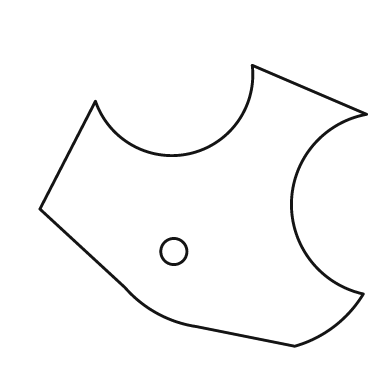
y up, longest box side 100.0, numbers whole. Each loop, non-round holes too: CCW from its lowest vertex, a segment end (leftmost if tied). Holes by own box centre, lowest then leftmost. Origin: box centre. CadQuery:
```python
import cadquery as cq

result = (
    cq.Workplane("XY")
    .moveTo(28.0, -43.0)
    .threePointArc((40.0, -37.0), (49.0, -27.0))
    .threePointArc((27.0, 1.0), (50.0, 28.0))
    .lineTo(15.0, 43.0)
    .threePointArc((-4.0, 16.0), (-33.0, 32.0))
    .lineTo(-50.0, -1.0)
    .lineTo(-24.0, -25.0)
    .threePointArc((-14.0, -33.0), (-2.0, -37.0))
    .close()
    .moveTo(-9.0, -14.0)
    .circle(4.0)
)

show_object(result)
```